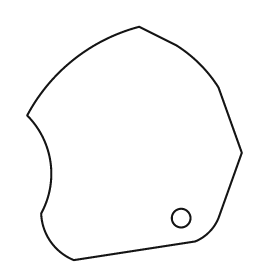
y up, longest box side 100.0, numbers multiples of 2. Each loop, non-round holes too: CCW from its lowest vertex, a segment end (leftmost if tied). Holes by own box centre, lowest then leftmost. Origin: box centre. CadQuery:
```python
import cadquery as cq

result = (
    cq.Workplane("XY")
    .moveTo(-26.0, -50.0)
    .lineTo(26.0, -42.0)
    .threePointArc((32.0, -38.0), (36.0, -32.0))
    .lineTo(46.0, -4.0)
    .lineTo(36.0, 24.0)
    .threePointArc((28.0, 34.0), (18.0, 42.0))
    .lineTo(2.0, 50.0)
    .threePointArc((-26.0, 36.0), (-46.0, 12.0))
    .threePointArc((-36.0, -8.0), (-40.0, -30.0))
    .threePointArc((-36.0, -42.0), (-26.0, -50.0))
    .close()
    .moveTo(20.0, -32.0)
    .circle(4.0)
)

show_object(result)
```